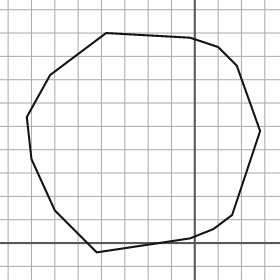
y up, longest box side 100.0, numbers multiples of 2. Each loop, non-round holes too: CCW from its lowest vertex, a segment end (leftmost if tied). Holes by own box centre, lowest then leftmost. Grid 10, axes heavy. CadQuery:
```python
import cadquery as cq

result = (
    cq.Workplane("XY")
    .moveTo(-42.0, -4.0)
    .lineTo(-2.0, 2.0)
    .lineTo(8.0, 6.0)
    .lineTo(16.0, 12.0)
    .lineTo(28.0, 48.0)
    .lineTo(18.0, 76.0)
    .lineTo(10.0, 84.0)
    .lineTo(-2.0, 88.0)
    .lineTo(-38.0, 90.0)
    .lineTo(-62.0, 72.0)
    .lineTo(-72.0, 54.0)
    .lineTo(-70.0, 36.0)
    .lineTo(-60.0, 14.0)
    .close()
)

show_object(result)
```